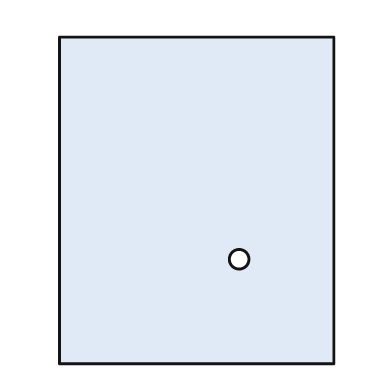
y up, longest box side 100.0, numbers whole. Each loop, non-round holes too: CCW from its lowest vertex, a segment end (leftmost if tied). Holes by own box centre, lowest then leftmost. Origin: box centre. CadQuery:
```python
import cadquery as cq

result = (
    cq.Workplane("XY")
    .moveTo(-42.0, -50.0)
    .lineTo(42.0, -50.0)
    .lineTo(42.0, 50.0)
    .lineTo(-42.0, 50.0)
    .close()
    .moveTo(13.0, -18.0)
    .circle(3.0)
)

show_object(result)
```